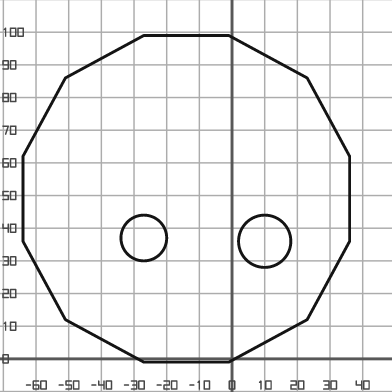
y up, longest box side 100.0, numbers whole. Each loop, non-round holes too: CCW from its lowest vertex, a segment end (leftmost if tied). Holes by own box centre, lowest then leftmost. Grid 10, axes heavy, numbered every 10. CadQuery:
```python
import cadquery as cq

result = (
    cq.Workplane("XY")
    .moveTo(-27.0, -1.0)
    .lineTo(-1.0, -1.0)
    .lineTo(23.0, 12.0)
    .lineTo(36.0, 36.0)
    .lineTo(36.0, 62.0)
    .lineTo(23.0, 86.0)
    .lineTo(-1.0, 99.0)
    .lineTo(-27.0, 99.0)
    .lineTo(-51.0, 86.0)
    .lineTo(-64.0, 62.0)
    .lineTo(-64.0, 36.0)
    .lineTo(-51.0, 12.0)
    .close()
    .moveTo(10.0, 36.0)
    .circle(8.0)
    .moveTo(-27.0, 37.0)
    .circle(7.0)
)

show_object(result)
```